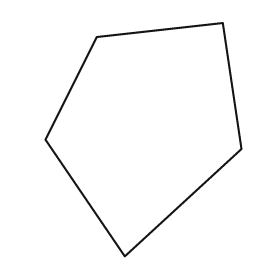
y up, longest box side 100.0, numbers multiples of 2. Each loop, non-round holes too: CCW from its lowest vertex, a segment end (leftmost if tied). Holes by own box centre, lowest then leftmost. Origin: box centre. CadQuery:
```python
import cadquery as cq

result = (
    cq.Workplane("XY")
    .moveTo(-8.0, -50.0)
    .lineTo(42.0, -4.0)
    .lineTo(34.0, 50.0)
    .lineTo(-20.0, 44.0)
    .lineTo(-42.0, 0.0)
    .close()
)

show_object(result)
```